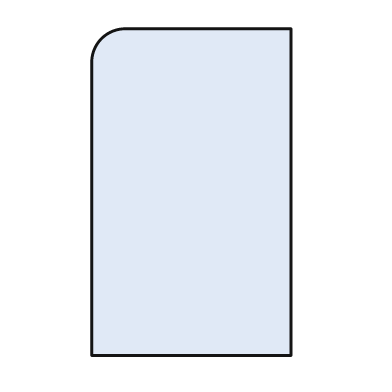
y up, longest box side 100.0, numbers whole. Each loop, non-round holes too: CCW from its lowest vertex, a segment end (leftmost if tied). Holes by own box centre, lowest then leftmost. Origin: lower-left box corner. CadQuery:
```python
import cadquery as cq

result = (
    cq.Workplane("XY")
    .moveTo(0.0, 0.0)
    .lineTo(61.0, 0.0)
    .lineTo(61.0, 100.0)
    .lineTo(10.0, 100.0)
    .threePointArc((3.0, 97.0), (0.0, 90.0))
    .close()
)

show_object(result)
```